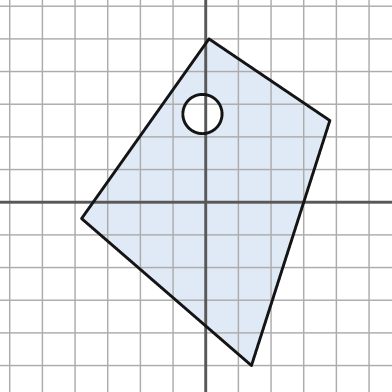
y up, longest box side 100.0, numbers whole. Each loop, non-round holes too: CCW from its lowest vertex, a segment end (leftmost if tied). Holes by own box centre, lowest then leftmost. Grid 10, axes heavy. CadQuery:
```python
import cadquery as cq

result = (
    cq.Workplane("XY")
    .moveTo(14.0, -50.0)
    .lineTo(38.0, 25.0)
    .lineTo(1.0, 50.0)
    .lineTo(-38.0, -5.0)
    .close()
    .moveTo(-1.0, 27.0)
    .circle(6.0)
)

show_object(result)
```